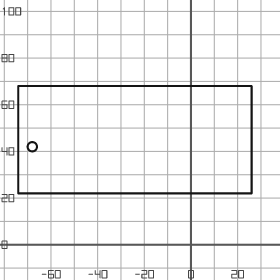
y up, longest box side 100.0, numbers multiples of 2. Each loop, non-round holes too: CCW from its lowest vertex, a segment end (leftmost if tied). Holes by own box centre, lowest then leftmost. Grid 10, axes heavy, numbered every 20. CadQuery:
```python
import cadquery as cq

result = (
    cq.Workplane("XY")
    .moveTo(-74.0, 22.0)
    .lineTo(26.0, 22.0)
    .lineTo(26.0, 68.0)
    .lineTo(-74.0, 68.0)
    .close()
    .moveTo(-68.0, 42.0)
    .circle(2.0)
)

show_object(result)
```